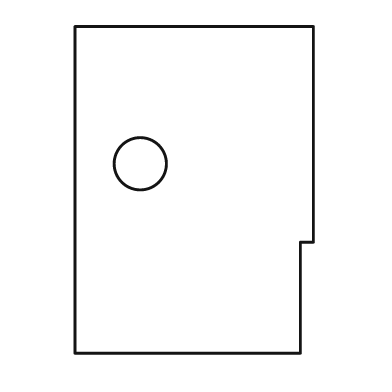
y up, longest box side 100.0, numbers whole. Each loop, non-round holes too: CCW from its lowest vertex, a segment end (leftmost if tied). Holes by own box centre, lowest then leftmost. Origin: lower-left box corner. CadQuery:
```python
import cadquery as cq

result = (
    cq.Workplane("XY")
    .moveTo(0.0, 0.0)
    .lineTo(69.0, 0.0)
    .lineTo(69.0, 34.0)
    .lineTo(73.0, 34.0)
    .lineTo(73.0, 100.0)
    .lineTo(0.0, 100.0)
    .close()
    .moveTo(20.0, 58.0)
    .circle(8.0)
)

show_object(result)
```